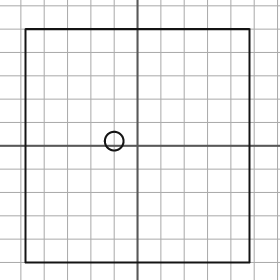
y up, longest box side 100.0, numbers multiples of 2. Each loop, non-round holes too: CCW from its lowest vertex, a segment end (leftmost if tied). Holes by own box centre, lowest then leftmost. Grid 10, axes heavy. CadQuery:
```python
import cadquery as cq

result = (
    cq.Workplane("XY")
    .moveTo(-48.0, -50.0)
    .lineTo(48.0, -50.0)
    .lineTo(48.0, 50.0)
    .lineTo(-48.0, 50.0)
    .close()
    .moveTo(-10.0, 2.0)
    .circle(4.0)
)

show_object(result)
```